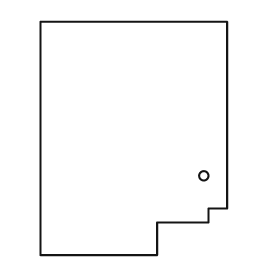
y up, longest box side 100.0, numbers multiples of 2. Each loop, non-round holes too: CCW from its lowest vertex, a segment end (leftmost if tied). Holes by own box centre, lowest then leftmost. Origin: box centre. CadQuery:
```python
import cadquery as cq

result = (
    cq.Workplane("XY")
    .moveTo(-40.0, -50.0)
    .lineTo(10.0, -50.0)
    .lineTo(10.0, -36.0)
    .lineTo(32.0, -36.0)
    .lineTo(32.0, -30.0)
    .lineTo(40.0, -30.0)
    .lineTo(40.0, 50.0)
    .lineTo(-40.0, 50.0)
    .close()
    .moveTo(30.0, -16.0)
    .circle(2.0)
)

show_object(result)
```